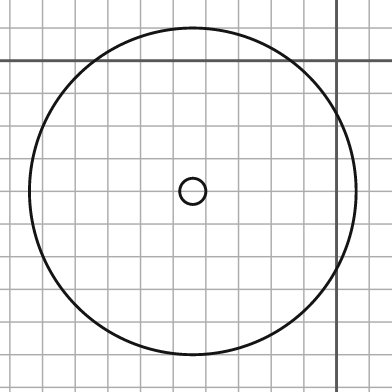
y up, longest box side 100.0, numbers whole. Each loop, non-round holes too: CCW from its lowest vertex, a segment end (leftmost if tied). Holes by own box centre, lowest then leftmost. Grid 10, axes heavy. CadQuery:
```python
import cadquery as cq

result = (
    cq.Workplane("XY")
    .moveTo(-44.0, -40.0)
    .circle(50.0)
    .moveTo(-44.0, -40.0)
    .circle(4.0)
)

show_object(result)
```